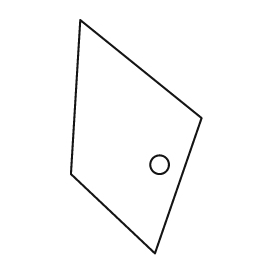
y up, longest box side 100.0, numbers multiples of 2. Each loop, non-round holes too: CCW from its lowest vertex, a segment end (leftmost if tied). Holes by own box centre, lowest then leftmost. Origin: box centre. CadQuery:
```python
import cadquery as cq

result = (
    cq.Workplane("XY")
    .moveTo(8.0, -50.0)
    .lineTo(28.0, 8.0)
    .lineTo(-24.0, 50.0)
    .lineTo(-28.0, -16.0)
    .close()
    .moveTo(10.0, -12.0)
    .circle(4.0)
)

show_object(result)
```